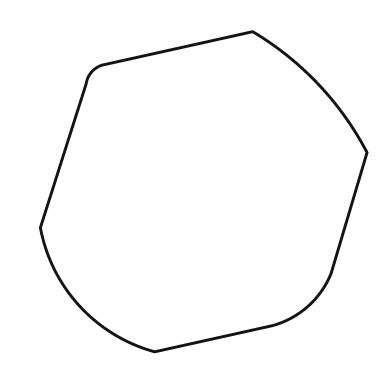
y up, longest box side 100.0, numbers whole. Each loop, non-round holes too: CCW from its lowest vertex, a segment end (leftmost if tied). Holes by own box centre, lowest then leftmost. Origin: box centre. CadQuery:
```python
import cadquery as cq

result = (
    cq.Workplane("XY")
    .moveTo(-15.0, -49.0)
    .lineTo(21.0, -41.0)
    .threePointArc((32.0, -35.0), (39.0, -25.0))
    .lineTo(50.0, 12.0)
    .threePointArc((35.0, 33.0), (15.0, 49.0))
    .lineTo(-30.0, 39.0)
    .threePointArc((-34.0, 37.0), (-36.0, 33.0))
    .lineTo(-50.0, -11.0)
    .threePointArc((-38.0, -35.0), (-15.0, -49.0))
    .close()
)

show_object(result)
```